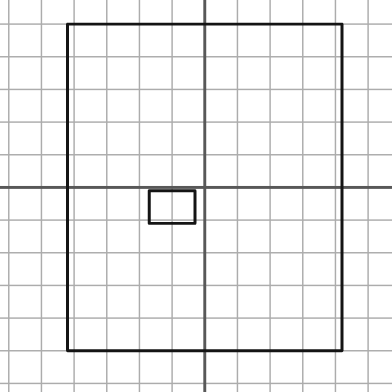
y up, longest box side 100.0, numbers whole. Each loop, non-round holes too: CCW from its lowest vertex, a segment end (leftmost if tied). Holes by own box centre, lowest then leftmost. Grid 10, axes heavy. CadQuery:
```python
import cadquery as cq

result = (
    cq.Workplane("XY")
    .moveTo(-42.0, -50.0)
    .lineTo(42.0, -50.0)
    .lineTo(42.0, 50.0)
    .lineTo(-42.0, 50.0)
    .close()
    .moveTo(-17.0, -11.0)
    .lineTo(-3.0, -11.0)
    .lineTo(-3.0, -1.0)
    .lineTo(-17.0, -1.0)
    .close()
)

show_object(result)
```